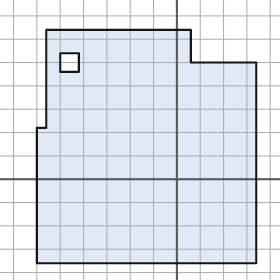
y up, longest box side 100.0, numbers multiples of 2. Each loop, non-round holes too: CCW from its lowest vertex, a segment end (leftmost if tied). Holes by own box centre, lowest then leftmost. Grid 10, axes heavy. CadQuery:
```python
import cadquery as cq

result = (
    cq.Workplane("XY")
    .moveTo(-60.0, -36.0)
    .lineTo(34.0, -36.0)
    .lineTo(34.0, 50.0)
    .lineTo(6.0, 50.0)
    .lineTo(6.0, 64.0)
    .lineTo(-56.0, 64.0)
    .lineTo(-56.0, 22.0)
    .lineTo(-60.0, 22.0)
    .close()
    .moveTo(-50.0, 46.0)
    .lineTo(-42.0, 46.0)
    .lineTo(-42.0, 54.0)
    .lineTo(-50.0, 54.0)
    .close()
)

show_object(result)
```